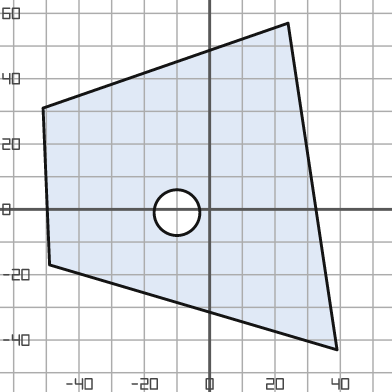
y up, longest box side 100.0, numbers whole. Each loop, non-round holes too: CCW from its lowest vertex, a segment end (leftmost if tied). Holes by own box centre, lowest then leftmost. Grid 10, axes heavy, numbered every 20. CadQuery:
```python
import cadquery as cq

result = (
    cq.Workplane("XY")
    .moveTo(39.0, -43.0)
    .lineTo(24.0, 57.0)
    .lineTo(-51.0, 31.0)
    .lineTo(-49.0, -17.0)
    .close()
    .moveTo(-10.0, -1.0)
    .circle(7.0)
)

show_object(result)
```